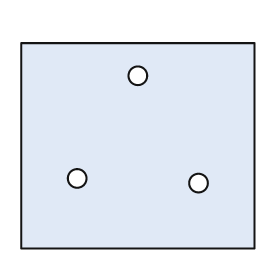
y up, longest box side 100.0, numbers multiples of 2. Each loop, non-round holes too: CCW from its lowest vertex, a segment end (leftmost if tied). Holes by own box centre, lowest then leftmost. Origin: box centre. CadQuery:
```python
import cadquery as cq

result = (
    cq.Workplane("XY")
    .moveTo(-50.0, -44.0)
    .lineTo(50.0, -44.0)
    .lineTo(50.0, 44.0)
    .lineTo(-50.0, 44.0)
    .close()
    .moveTo(26.0, -16.0)
    .circle(4.0)
    .moveTo(-26.0, -14.0)
    .circle(4.0)
    .moveTo(0.0, 30.0)
    .circle(4.0)
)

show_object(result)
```